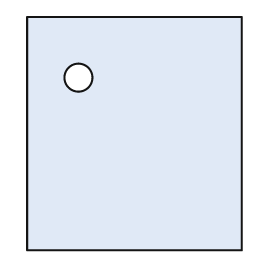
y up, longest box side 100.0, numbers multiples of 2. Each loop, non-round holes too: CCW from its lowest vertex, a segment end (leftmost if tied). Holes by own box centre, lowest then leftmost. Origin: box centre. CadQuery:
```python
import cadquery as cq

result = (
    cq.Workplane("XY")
    .moveTo(-46.0, -50.0)
    .lineTo(46.0, -50.0)
    .lineTo(46.0, 50.0)
    .lineTo(-46.0, 50.0)
    .close()
    .moveTo(-24.0, 24.0)
    .circle(6.0)
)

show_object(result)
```